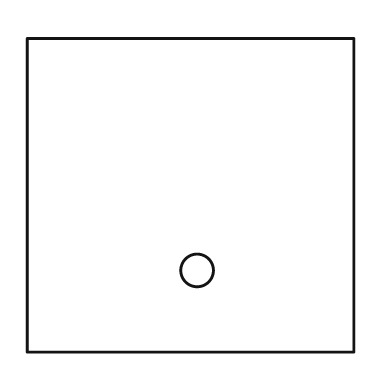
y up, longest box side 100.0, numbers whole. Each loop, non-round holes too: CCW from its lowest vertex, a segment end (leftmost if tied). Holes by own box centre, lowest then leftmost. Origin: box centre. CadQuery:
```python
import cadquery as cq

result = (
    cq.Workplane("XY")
    .moveTo(-50.0, -48.0)
    .lineTo(50.0, -48.0)
    .lineTo(50.0, 48.0)
    .lineTo(-50.0, 48.0)
    .close()
    .moveTo(2.0, -23.0)
    .circle(5.0)
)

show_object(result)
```